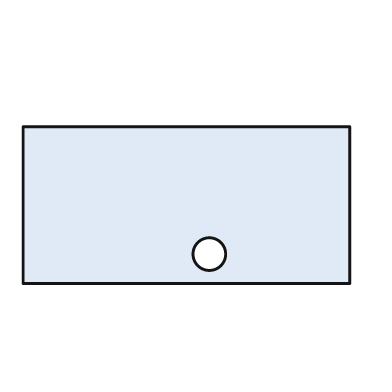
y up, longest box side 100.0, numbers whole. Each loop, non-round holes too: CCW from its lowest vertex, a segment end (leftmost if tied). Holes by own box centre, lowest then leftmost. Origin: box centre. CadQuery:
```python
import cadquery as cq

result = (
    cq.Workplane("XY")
    .moveTo(-50.0, -24.0)
    .lineTo(50.0, -24.0)
    .lineTo(50.0, 24.0)
    .lineTo(-50.0, 24.0)
    .close()
    .moveTo(7.0, -15.0)
    .circle(5.0)
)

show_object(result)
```